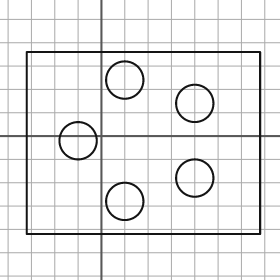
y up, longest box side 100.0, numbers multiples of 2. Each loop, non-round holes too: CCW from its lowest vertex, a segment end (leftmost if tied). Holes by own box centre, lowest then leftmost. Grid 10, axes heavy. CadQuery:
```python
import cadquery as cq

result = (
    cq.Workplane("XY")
    .moveTo(-32.0, -42.0)
    .lineTo(68.0, -42.0)
    .lineTo(68.0, 36.0)
    .lineTo(-32.0, 36.0)
    .close()
    .moveTo(10.0, -28.0)
    .circle(8.0)
    .moveTo(40.0, -18.0)
    .circle(8.0)
    .moveTo(-10.0, -2.0)
    .circle(8.0)
    .moveTo(40.0, 14.0)
    .circle(8.0)
    .moveTo(10.0, 24.0)
    .circle(8.0)
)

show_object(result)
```